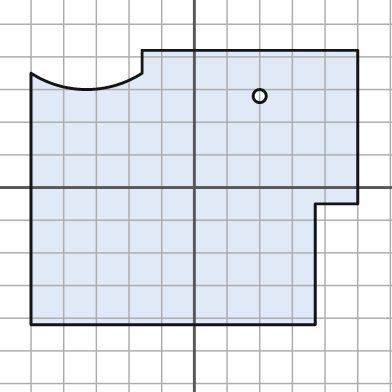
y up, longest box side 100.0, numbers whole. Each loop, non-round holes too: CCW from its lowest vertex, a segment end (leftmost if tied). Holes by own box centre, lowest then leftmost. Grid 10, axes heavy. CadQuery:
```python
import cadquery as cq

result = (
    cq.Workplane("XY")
    .moveTo(-50.0, -42.0)
    .lineTo(37.0, -42.0)
    .lineTo(37.0, -5.0)
    .lineTo(50.0, -5.0)
    .lineTo(50.0, 42.0)
    .lineTo(-16.0, 42.0)
    .lineTo(-16.0, 35.0)
    .threePointArc((-33.0, 30.0), (-50.0, 35.0))
    .close()
    .moveTo(20.0, 28.0)
    .circle(2.0)
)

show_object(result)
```